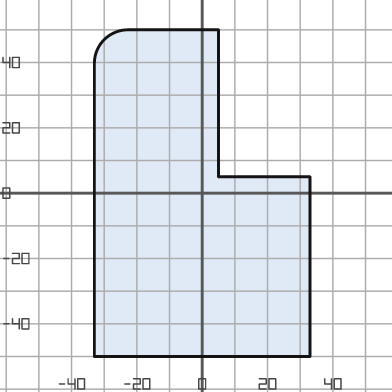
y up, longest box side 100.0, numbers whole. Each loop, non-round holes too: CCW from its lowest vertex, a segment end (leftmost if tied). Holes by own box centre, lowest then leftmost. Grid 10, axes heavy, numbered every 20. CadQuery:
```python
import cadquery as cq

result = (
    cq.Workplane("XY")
    .moveTo(-33.0, -50.0)
    .lineTo(33.0, -50.0)
    .lineTo(33.0, 5.0)
    .lineTo(5.0, 5.0)
    .lineTo(5.0, 50.0)
    .lineTo(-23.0, 50.0)
    .threePointArc((-30.0, 47.0), (-33.0, 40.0))
    .close()
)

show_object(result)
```